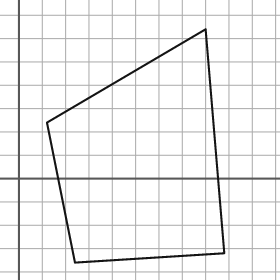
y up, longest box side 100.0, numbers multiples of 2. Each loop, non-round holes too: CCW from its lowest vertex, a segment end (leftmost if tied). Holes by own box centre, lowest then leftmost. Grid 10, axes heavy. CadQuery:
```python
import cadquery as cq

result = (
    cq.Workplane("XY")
    .moveTo(24.0, -36.0)
    .lineTo(88.0, -32.0)
    .lineTo(80.0, 64.0)
    .lineTo(12.0, 24.0)
    .close()
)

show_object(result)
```